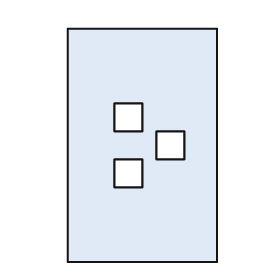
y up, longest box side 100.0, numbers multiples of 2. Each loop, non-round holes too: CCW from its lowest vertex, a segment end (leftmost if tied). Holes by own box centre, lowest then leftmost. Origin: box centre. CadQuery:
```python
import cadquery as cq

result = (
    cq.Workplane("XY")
    .moveTo(-32.0, -50.0)
    .lineTo(32.0, -50.0)
    .lineTo(32.0, 50.0)
    .lineTo(-32.0, 50.0)
    .close()
    .moveTo(-12.0, -18.0)
    .lineTo(0.0, -18.0)
    .lineTo(0.0, -6.0)
    .lineTo(-12.0, -6.0)
    .close()
    .moveTo(6.0, -6.0)
    .lineTo(18.0, -6.0)
    .lineTo(18.0, 6.0)
    .lineTo(6.0, 6.0)
    .close()
    .moveTo(-12.0, 6.0)
    .lineTo(0.0, 6.0)
    .lineTo(0.0, 18.0)
    .lineTo(-12.0, 18.0)
    .close()
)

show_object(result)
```